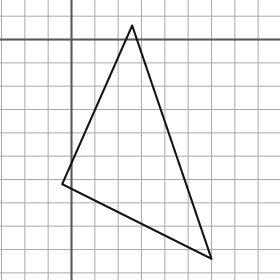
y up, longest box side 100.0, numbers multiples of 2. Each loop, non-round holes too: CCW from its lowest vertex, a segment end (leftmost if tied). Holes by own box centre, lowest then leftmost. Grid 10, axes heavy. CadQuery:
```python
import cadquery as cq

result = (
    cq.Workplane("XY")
    .moveTo(60.0, -94.0)
    .lineTo(26.0, 6.0)
    .lineTo(-4.0, -62.0)
    .close()
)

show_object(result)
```